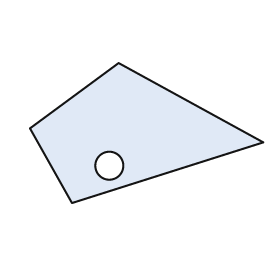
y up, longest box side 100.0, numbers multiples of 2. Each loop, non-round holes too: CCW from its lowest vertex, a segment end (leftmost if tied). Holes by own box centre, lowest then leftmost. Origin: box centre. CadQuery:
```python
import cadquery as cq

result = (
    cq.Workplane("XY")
    .moveTo(-32.0, -30.0)
    .lineTo(50.0, -4.0)
    .lineTo(-12.0, 30.0)
    .lineTo(-50.0, 2.0)
    .close()
    .moveTo(-16.0, -14.0)
    .circle(6.0)
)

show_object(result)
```